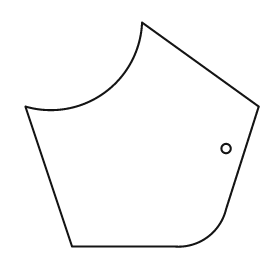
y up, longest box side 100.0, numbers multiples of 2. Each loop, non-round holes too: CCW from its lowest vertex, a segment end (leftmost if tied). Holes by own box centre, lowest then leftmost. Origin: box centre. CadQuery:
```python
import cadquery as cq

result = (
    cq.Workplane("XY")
    .moveTo(-30.0, -48.0)
    .lineTo(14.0, -48.0)
    .threePointArc((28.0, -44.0), (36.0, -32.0))
    .lineTo(50.0, 12.0)
    .lineTo(0.0, 48.0)
    .threePointArc((-16.0, 18.0), (-50.0, 12.0))
    .close()
    .moveTo(36.0, -6.0)
    .circle(2.0)
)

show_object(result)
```